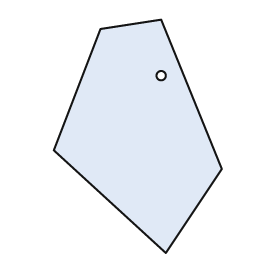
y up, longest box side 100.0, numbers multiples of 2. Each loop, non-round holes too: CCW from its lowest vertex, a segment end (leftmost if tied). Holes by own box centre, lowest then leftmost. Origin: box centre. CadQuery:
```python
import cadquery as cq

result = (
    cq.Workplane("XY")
    .moveTo(12.0, -50.0)
    .lineTo(36.0, -14.0)
    .lineTo(10.0, 50.0)
    .lineTo(-16.0, 46.0)
    .lineTo(-36.0, -6.0)
    .close()
    .moveTo(10.0, 26.0)
    .circle(2.0)
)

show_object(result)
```